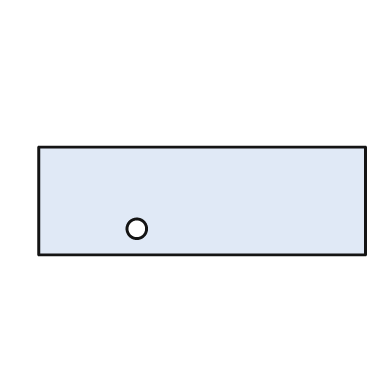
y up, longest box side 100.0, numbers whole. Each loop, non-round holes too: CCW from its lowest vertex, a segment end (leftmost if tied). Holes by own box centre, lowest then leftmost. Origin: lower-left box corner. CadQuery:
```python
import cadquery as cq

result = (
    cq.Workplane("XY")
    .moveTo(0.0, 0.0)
    .lineTo(100.0, 0.0)
    .lineTo(100.0, 33.0)
    .lineTo(0.0, 33.0)
    .close()
    .moveTo(30.0, 8.0)
    .circle(3.0)
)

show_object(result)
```